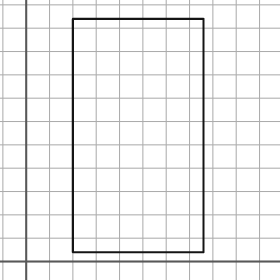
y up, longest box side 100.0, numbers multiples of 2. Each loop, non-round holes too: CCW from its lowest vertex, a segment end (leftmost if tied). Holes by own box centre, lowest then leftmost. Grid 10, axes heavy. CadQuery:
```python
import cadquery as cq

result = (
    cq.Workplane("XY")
    .moveTo(20.0, 4.0)
    .lineTo(76.0, 4.0)
    .lineTo(76.0, 104.0)
    .lineTo(20.0, 104.0)
    .close()
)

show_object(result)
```